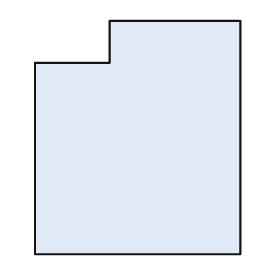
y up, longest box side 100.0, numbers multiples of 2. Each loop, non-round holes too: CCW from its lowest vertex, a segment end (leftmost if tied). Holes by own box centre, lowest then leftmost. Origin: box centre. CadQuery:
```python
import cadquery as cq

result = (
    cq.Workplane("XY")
    .moveTo(-44.0, -50.0)
    .lineTo(44.0, -50.0)
    .lineTo(44.0, 50.0)
    .lineTo(-12.0, 50.0)
    .lineTo(-12.0, 32.0)
    .lineTo(-44.0, 32.0)
    .close()
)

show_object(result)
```